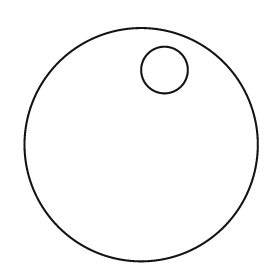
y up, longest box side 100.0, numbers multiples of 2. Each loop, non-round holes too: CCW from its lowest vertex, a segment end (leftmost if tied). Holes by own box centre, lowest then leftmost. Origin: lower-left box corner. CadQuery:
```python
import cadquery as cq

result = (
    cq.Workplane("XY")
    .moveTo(50.0, 50.0)
    .circle(50.0)
    .moveTo(60.0, 82.0)
    .circle(10.0)
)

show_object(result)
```